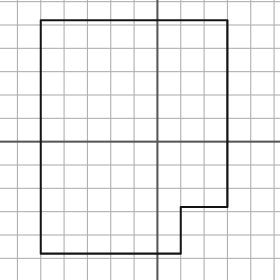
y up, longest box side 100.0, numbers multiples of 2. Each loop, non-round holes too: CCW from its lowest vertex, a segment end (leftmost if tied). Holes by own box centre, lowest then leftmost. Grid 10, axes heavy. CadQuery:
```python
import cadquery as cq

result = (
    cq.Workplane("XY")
    .moveTo(-50.0, -48.0)
    .lineTo(10.0, -48.0)
    .lineTo(10.0, -28.0)
    .lineTo(30.0, -28.0)
    .lineTo(30.0, 52.0)
    .lineTo(-50.0, 52.0)
    .close()
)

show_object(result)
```